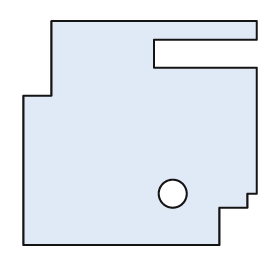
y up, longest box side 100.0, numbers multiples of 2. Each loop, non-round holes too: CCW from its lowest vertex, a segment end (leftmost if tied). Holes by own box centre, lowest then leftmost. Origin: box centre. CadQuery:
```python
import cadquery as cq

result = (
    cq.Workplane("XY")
    .moveTo(-50.0, -48.0)
    .lineTo(34.0, -48.0)
    .lineTo(34.0, -32.0)
    .lineTo(46.0, -32.0)
    .lineTo(46.0, -26.0)
    .lineTo(50.0, -26.0)
    .lineTo(50.0, 28.0)
    .lineTo(6.0, 28.0)
    .lineTo(6.0, 40.0)
    .lineTo(50.0, 40.0)
    .lineTo(50.0, 48.0)
    .lineTo(-38.0, 48.0)
    .lineTo(-38.0, 16.0)
    .lineTo(-50.0, 16.0)
    .close()
    .moveTo(14.0, -26.0)
    .circle(6.0)
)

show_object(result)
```